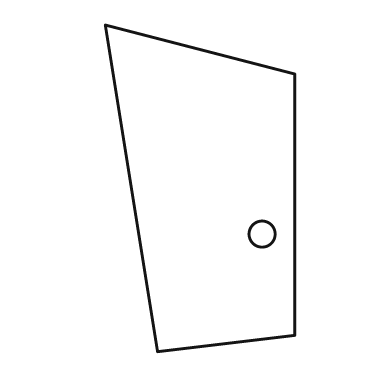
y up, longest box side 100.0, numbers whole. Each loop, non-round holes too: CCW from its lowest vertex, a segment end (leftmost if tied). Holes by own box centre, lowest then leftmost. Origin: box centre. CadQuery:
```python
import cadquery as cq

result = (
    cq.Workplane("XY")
    .moveTo(-13.0, -50.0)
    .lineTo(29.0, -45.0)
    .lineTo(29.0, 35.0)
    .lineTo(-29.0, 50.0)
    .close()
    .moveTo(19.0, -14.0)
    .circle(4.0)
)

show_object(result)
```